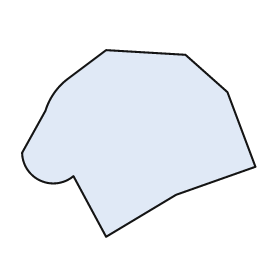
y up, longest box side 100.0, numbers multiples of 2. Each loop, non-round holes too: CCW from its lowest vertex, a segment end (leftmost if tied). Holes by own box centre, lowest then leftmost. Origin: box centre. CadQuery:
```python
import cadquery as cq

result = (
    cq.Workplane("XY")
    .moveTo(-14.0, -40.0)
    .lineTo(16.0, -22.0)
    .lineTo(50.0, -10.0)
    .lineTo(38.0, 22.0)
    .lineTo(20.0, 38.0)
    .lineTo(-14.0, 40.0)
    .lineTo(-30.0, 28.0)
    .threePointArc((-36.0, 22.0), (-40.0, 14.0))
    .lineTo(-50.0, -4.0)
    .threePointArc((-42.0, -16.0), (-28.0, -14.0))
    .close()
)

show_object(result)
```